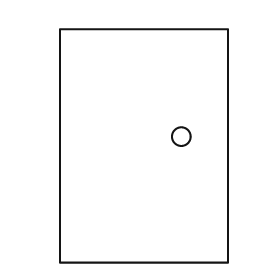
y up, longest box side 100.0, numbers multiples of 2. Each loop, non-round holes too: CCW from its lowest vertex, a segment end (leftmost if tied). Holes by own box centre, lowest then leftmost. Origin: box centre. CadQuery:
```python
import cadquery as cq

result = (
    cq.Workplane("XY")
    .moveTo(-36.0, -50.0)
    .lineTo(36.0, -50.0)
    .lineTo(36.0, 50.0)
    .lineTo(-36.0, 50.0)
    .close()
    .moveTo(16.0, 4.0)
    .circle(4.0)
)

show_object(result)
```